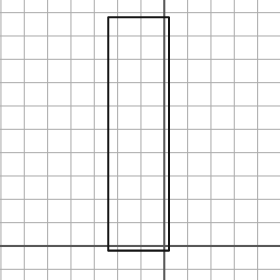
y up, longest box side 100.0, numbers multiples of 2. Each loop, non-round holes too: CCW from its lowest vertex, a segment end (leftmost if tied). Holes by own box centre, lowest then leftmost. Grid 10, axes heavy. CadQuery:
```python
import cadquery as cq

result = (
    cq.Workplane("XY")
    .moveTo(-24.0, -2.0)
    .lineTo(2.0, -2.0)
    .lineTo(2.0, 98.0)
    .lineTo(-24.0, 98.0)
    .close()
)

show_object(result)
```